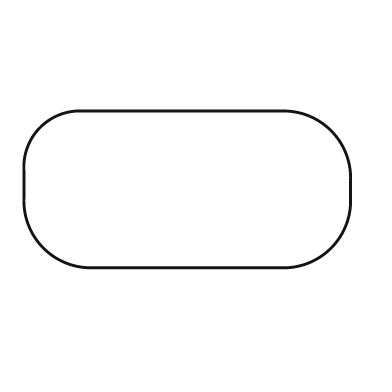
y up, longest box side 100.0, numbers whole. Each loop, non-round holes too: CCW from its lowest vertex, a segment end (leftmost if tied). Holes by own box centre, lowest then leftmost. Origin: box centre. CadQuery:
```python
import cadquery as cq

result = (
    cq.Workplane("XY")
    .moveTo(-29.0, -24.0)
    .lineTo(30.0, -24.0)
    .threePointArc((44.0, -18.0), (50.0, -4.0))
    .lineTo(50.0, 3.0)
    .threePointArc((44.0, 18.0), (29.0, 24.0))
    .lineTo(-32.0, 24.0)
    .threePointArc((-45.0, 19.0), (-50.0, 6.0))
    .lineTo(-50.0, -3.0)
    .threePointArc((-44.0, -18.0), (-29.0, -24.0))
    .close()
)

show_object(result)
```